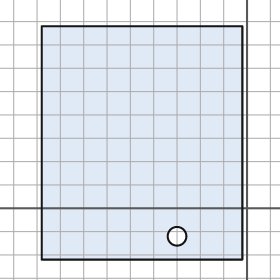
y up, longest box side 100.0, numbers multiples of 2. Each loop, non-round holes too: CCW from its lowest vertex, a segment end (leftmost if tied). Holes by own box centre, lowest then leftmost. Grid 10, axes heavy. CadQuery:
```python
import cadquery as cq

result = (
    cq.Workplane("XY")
    .moveTo(-88.0, -22.0)
    .lineTo(-2.0, -22.0)
    .lineTo(-2.0, 78.0)
    .lineTo(-88.0, 78.0)
    .close()
    .moveTo(-30.0, -12.0)
    .circle(4.0)
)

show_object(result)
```